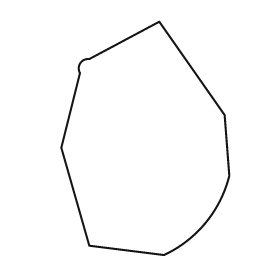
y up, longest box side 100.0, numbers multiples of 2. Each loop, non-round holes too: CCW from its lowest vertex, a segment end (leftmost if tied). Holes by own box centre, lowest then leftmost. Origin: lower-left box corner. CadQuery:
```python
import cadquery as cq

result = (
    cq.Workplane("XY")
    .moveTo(44.0, 0.0)
    .threePointArc((62.0, 14.0), (72.0, 34.0))
    .lineTo(70.0, 60.0)
    .lineTo(42.0, 100.0)
    .lineTo(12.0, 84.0)
    .threePointArc((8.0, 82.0), (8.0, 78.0))
    .lineTo(0.0, 46.0)
    .lineTo(12.0, 4.0)
    .close()
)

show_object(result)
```